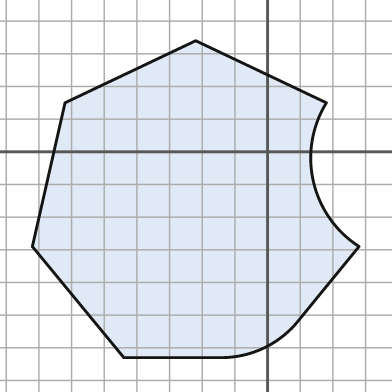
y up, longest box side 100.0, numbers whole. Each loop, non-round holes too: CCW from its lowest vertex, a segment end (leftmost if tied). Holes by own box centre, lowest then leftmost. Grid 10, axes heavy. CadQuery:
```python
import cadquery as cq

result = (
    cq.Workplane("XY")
    .moveTo(-44.0, -63.0)
    .lineTo(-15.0, -63.0)
    .threePointArc((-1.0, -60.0), (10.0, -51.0))
    .lineTo(28.0, -29.0)
    .threePointArc((14.0, -9.0), (18.0, 15.0))
    .lineTo(-22.0, 34.0)
    .lineTo(-62.0, 15.0)
    .lineTo(-72.0, -29.0)
    .close()
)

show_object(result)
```